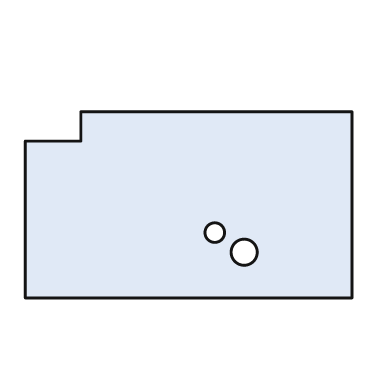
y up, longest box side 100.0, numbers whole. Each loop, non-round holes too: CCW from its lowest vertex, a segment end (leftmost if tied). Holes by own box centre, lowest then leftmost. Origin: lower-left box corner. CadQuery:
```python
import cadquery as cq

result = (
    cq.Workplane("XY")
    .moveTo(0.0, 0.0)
    .lineTo(100.0, 0.0)
    .lineTo(100.0, 57.0)
    .lineTo(17.0, 57.0)
    .lineTo(17.0, 48.0)
    .lineTo(0.0, 48.0)
    .close()
    .moveTo(67.0, 14.0)
    .circle(4.0)
    .moveTo(58.0, 20.0)
    .circle(3.0)
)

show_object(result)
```